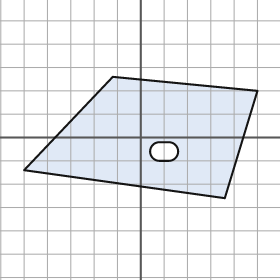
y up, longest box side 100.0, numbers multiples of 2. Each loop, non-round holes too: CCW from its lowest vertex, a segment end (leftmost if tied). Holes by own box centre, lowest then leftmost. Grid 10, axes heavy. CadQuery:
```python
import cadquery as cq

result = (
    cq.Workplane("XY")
    .moveTo(36.0, -26.0)
    .lineTo(50.0, 20.0)
    .lineTo(-12.0, 26.0)
    .lineTo(-50.0, -14.0)
    .close()
    .moveTo(8.0, -10.0)
    .lineTo(12.0, -10.0)
    .threePointArc((16.0, -6.0), (12.0, -2.0))
    .lineTo(8.0, -2.0)
    .threePointArc((4.0, -6.0), (8.0, -10.0))
    .close()
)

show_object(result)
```